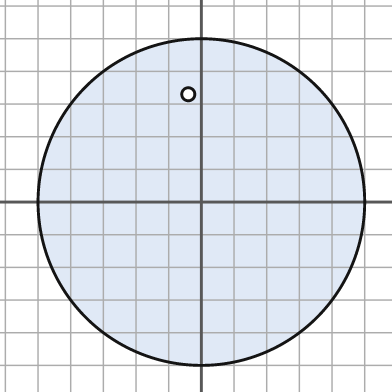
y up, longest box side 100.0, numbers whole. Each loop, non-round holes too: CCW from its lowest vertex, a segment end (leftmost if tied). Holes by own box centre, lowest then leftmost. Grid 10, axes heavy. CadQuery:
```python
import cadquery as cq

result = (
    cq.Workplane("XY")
    .moveTo(0.0, 0.0)
    .circle(50.0)
    .moveTo(-4.0, 33.0)
    .circle(2.0)
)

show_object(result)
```